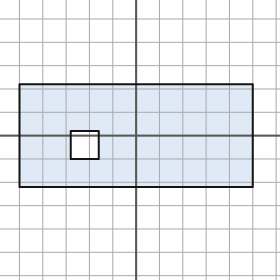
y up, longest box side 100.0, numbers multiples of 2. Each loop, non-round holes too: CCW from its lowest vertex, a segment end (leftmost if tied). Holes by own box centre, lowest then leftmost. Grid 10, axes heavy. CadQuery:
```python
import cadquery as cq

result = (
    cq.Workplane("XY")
    .moveTo(-50.0, -22.0)
    .lineTo(50.0, -22.0)
    .lineTo(50.0, 22.0)
    .lineTo(-50.0, 22.0)
    .close()
    .moveTo(-28.0, -10.0)
    .lineTo(-16.0, -10.0)
    .lineTo(-16.0, 2.0)
    .lineTo(-28.0, 2.0)
    .close()
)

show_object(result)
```